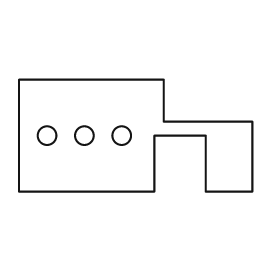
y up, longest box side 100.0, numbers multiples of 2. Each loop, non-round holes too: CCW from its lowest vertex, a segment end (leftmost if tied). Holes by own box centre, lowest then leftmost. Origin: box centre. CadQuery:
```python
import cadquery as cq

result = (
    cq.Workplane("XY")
    .moveTo(-50.0, -24.0)
    .lineTo(8.0, -24.0)
    .lineTo(8.0, 0.0)
    .lineTo(30.0, 0.0)
    .lineTo(30.0, -24.0)
    .lineTo(50.0, -24.0)
    .lineTo(50.0, 6.0)
    .lineTo(12.0, 6.0)
    .lineTo(12.0, 24.0)
    .lineTo(-50.0, 24.0)
    .close()
    .moveTo(-38.0, 0.0)
    .circle(4.0)
    .moveTo(-22.0, 0.0)
    .circle(4.0)
    .moveTo(-6.0, 0.0)
    .circle(4.0)
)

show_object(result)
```